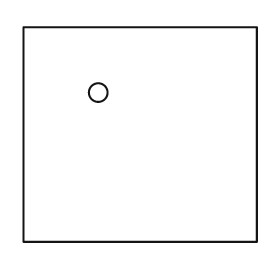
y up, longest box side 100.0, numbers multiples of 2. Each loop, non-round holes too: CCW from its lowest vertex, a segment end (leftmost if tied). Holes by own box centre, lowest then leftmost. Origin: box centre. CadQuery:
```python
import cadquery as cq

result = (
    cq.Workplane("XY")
    .moveTo(-50.0, -46.0)
    .lineTo(50.0, -46.0)
    .lineTo(50.0, 46.0)
    .lineTo(-50.0, 46.0)
    .close()
    .moveTo(-18.0, 18.0)
    .circle(4.0)
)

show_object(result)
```